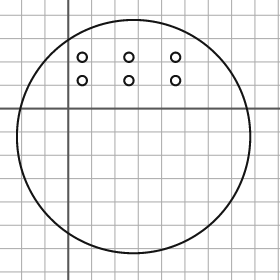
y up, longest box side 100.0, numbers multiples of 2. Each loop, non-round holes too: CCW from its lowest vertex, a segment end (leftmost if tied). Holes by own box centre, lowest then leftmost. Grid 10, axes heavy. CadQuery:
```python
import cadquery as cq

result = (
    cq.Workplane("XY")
    .moveTo(28.0, -12.0)
    .circle(50.0)
    .moveTo(6.0, 12.0)
    .circle(2.0)
    .moveTo(26.0, 12.0)
    .circle(2.0)
    .moveTo(46.0, 12.0)
    .circle(2.0)
    .moveTo(6.0, 22.0)
    .circle(2.0)
    .moveTo(26.0, 22.0)
    .circle(2.0)
    .moveTo(46.0, 22.0)
    .circle(2.0)
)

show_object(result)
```